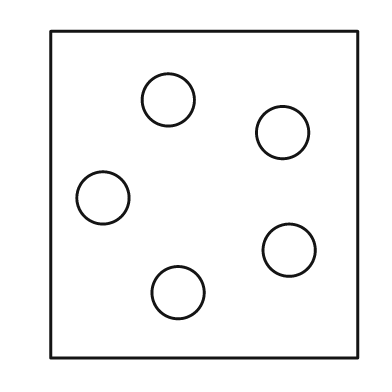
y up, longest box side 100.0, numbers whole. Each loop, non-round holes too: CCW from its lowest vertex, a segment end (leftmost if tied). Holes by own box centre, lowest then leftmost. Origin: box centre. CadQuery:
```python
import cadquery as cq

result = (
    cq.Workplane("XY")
    .moveTo(-47.0, -50.0)
    .lineTo(47.0, -50.0)
    .lineTo(47.0, 50.0)
    .lineTo(-47.0, 50.0)
    .close()
    .moveTo(-8.0, -30.0)
    .circle(8.0)
    .moveTo(26.0, -17.0)
    .circle(8.0)
    .moveTo(-31.0, -1.0)
    .circle(8.0)
    .moveTo(24.0, 19.0)
    .circle(8.0)
    .moveTo(-11.0, 29.0)
    .circle(8.0)
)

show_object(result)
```